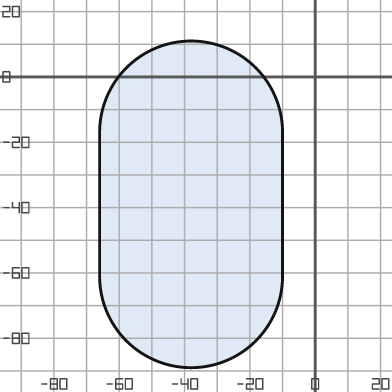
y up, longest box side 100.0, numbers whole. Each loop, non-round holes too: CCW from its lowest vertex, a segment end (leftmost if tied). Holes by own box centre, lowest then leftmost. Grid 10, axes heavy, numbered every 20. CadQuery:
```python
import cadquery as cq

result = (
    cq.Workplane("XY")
    .moveTo(-66.0, -61.0)
    .threePointArc((-38.0, -89.0), (-10.0, -61.0))
    .lineTo(-10.0, -17.0)
    .threePointArc((-38.0, 11.0), (-66.0, -17.0))
    .close()
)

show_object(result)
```